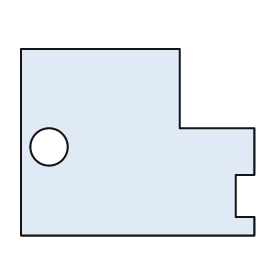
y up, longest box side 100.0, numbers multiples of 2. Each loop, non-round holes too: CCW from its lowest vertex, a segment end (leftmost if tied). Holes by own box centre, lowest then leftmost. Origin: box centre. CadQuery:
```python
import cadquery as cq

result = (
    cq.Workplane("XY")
    .moveTo(-50.0, -40.0)
    .lineTo(50.0, -40.0)
    .lineTo(50.0, -32.0)
    .lineTo(42.0, -32.0)
    .lineTo(42.0, -14.0)
    .lineTo(50.0, -14.0)
    .lineTo(50.0, 6.0)
    .lineTo(18.0, 6.0)
    .lineTo(18.0, 40.0)
    .lineTo(-50.0, 40.0)
    .close()
    .moveTo(-38.0, -2.0)
    .circle(8.0)
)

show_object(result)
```